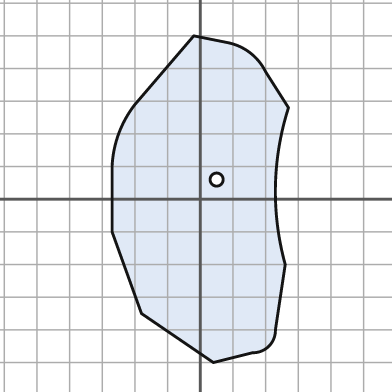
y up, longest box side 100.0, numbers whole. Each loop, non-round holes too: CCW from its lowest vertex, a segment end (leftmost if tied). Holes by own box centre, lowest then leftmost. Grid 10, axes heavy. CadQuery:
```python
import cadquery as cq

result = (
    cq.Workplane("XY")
    .moveTo(4.0, -50.0)
    .lineTo(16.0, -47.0)
    .threePointArc((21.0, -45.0), (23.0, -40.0))
    .lineTo(26.0, -20.0)
    .threePointArc((23.0, 4.0), (27.0, 28.0))
    .lineTo(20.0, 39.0)
    .threePointArc((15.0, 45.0), (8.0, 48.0))
    .lineTo(-2.0, 50.0)
    .lineTo(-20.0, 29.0)
    .threePointArc((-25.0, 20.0), (-27.0, 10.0))
    .lineTo(-27.0, -10.0)
    .lineTo(-18.0, -35.0)
    .close()
    .moveTo(5.0, 6.0)
    .circle(2.0)
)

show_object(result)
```